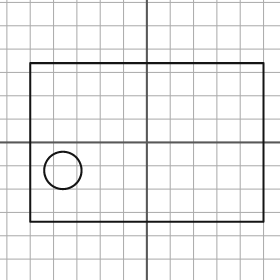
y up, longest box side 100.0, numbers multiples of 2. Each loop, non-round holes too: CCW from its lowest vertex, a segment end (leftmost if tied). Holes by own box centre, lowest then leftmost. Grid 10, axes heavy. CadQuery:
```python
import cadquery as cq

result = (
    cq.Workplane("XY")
    .moveTo(-50.0, -34.0)
    .lineTo(50.0, -34.0)
    .lineTo(50.0, 34.0)
    .lineTo(-50.0, 34.0)
    .close()
    .moveTo(-36.0, -12.0)
    .circle(8.0)
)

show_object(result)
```